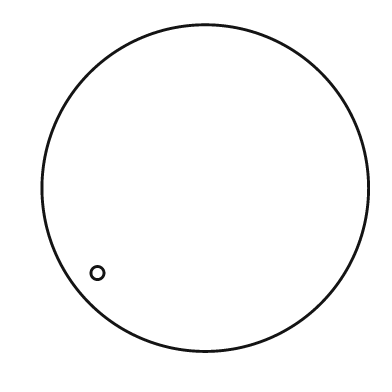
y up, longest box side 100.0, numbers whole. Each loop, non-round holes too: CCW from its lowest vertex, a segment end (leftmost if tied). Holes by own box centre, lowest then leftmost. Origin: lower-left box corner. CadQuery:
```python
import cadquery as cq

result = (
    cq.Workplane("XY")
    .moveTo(50.0, 50.0)
    .circle(50.0)
    .moveTo(17.0, 24.0)
    .circle(2.0)
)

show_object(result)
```